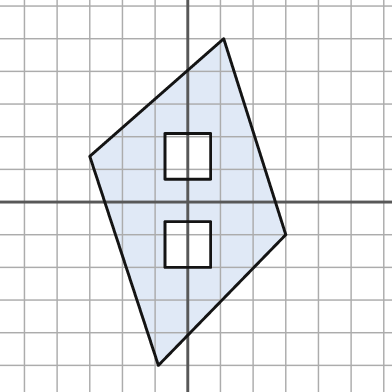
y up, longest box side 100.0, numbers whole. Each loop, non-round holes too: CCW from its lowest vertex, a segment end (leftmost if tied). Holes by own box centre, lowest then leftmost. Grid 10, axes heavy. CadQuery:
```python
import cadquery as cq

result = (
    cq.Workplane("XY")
    .moveTo(-9.0, -50.0)
    .lineTo(30.0, -10.0)
    .lineTo(11.0, 50.0)
    .lineTo(-30.0, 14.0)
    .close()
    .moveTo(-7.0, -20.0)
    .lineTo(7.0, -20.0)
    .lineTo(7.0, -6.0)
    .lineTo(-7.0, -6.0)
    .close()
    .moveTo(-7.0, 7.0)
    .lineTo(7.0, 7.0)
    .lineTo(7.0, 21.0)
    .lineTo(-7.0, 21.0)
    .close()
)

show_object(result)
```